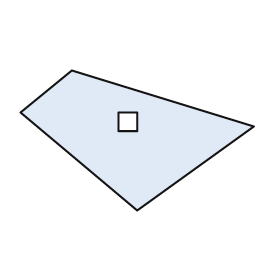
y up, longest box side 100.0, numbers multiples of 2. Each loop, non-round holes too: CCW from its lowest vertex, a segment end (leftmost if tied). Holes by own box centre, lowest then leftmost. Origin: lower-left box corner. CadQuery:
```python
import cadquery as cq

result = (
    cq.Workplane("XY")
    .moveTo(50.0, 0.0)
    .lineTo(100.0, 36.0)
    .lineTo(22.0, 60.0)
    .lineTo(0.0, 42.0)
    .close()
    .moveTo(42.0, 34.0)
    .lineTo(50.0, 34.0)
    .lineTo(50.0, 42.0)
    .lineTo(42.0, 42.0)
    .close()
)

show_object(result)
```